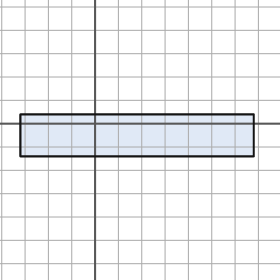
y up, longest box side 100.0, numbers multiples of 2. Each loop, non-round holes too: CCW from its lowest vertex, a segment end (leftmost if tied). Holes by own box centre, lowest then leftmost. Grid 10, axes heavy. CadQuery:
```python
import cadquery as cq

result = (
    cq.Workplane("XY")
    .moveTo(-32.0, -14.0)
    .lineTo(68.0, -14.0)
    .lineTo(68.0, 4.0)
    .lineTo(-32.0, 4.0)
    .close()
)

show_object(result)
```